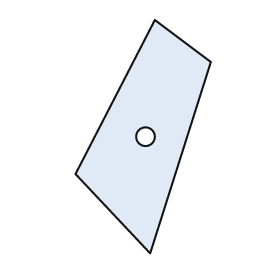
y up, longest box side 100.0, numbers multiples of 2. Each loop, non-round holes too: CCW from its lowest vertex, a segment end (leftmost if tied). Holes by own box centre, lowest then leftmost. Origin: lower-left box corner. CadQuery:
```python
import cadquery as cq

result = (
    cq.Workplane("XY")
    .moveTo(32.0, 0.0)
    .lineTo(58.0, 82.0)
    .lineTo(34.0, 100.0)
    .lineTo(0.0, 34.0)
    .close()
    .moveTo(30.0, 50.0)
    .circle(4.0)
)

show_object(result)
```